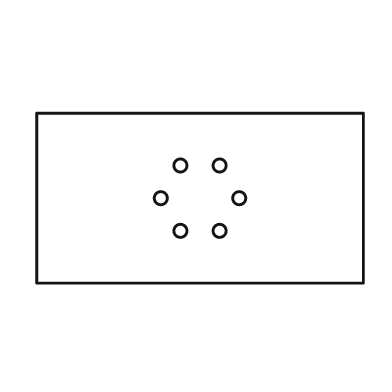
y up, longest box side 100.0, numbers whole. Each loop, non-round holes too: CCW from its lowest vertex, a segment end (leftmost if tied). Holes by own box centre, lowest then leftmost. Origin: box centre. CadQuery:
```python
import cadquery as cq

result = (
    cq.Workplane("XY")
    .moveTo(-50.0, -26.0)
    .lineTo(50.0, -26.0)
    .lineTo(50.0, 26.0)
    .lineTo(-50.0, 26.0)
    .close()
    .moveTo(-6.0, -10.0)
    .circle(2.0)
    .moveTo(6.0, -10.0)
    .circle(2.0)
    .moveTo(-12.0, 0.0)
    .circle(2.0)
    .moveTo(12.0, 0.0)
    .circle(2.0)
    .moveTo(-6.0, 10.0)
    .circle(2.0)
    .moveTo(6.0, 10.0)
    .circle(2.0)
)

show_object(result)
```